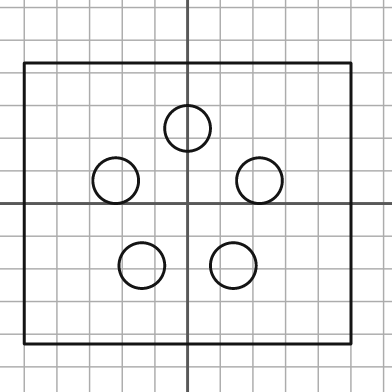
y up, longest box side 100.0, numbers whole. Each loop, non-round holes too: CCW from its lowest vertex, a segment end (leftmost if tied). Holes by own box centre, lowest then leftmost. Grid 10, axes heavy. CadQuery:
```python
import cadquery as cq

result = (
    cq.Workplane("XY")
    .moveTo(-50.0, -43.0)
    .lineTo(50.0, -43.0)
    .lineTo(50.0, 43.0)
    .lineTo(-50.0, 43.0)
    .close()
    .moveTo(-14.0, -19.0)
    .circle(7.0)
    .moveTo(14.0, -19.0)
    .circle(7.0)
    .moveTo(-22.0, 7.0)
    .circle(7.0)
    .moveTo(22.0, 7.0)
    .circle(7.0)
    .moveTo(0.0, 23.0)
    .circle(7.0)
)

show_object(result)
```